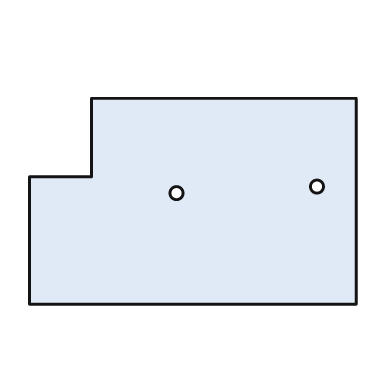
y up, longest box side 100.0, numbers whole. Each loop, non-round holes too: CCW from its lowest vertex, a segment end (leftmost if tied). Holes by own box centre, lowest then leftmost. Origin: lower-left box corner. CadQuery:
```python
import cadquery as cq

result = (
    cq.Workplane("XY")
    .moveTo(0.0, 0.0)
    .lineTo(100.0, 0.0)
    .lineTo(100.0, 63.0)
    .lineTo(19.0, 63.0)
    .lineTo(19.0, 39.0)
    .lineTo(0.0, 39.0)
    .close()
    .moveTo(45.0, 34.0)
    .circle(2.0)
    .moveTo(88.0, 36.0)
    .circle(2.0)
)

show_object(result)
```